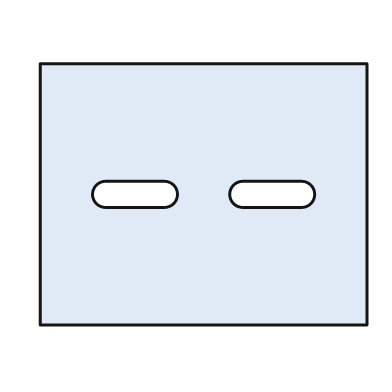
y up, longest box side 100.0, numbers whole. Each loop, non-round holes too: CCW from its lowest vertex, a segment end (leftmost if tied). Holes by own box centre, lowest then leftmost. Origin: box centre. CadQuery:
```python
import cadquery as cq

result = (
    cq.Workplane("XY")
    .moveTo(-50.0, -40.0)
    .lineTo(50.0, -40.0)
    .lineTo(50.0, 40.0)
    .lineTo(-50.0, 40.0)
    .close()
    .moveTo(-30.0, -4.0)
    .lineTo(-12.0, -4.0)
    .threePointArc((-8.0, 0.0), (-12.0, 4.0))
    .lineTo(-30.0, 4.0)
    .threePointArc((-34.0, 0.0), (-30.0, -4.0))
    .close()
    .moveTo(12.0, -4.0)
    .lineTo(30.0, -4.0)
    .threePointArc((34.0, 0.0), (30.0, 4.0))
    .lineTo(12.0, 4.0)
    .threePointArc((8.0, 0.0), (12.0, -4.0))
    .close()
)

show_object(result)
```